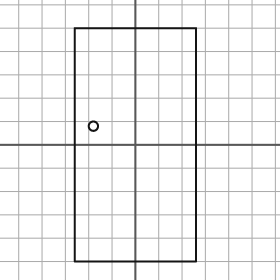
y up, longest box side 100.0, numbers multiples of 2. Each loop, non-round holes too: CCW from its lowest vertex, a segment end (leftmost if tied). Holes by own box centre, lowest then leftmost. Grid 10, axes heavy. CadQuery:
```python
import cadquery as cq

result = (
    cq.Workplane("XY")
    .moveTo(-26.0, -50.0)
    .lineTo(26.0, -50.0)
    .lineTo(26.0, 50.0)
    .lineTo(-26.0, 50.0)
    .close()
    .moveTo(-18.0, 8.0)
    .circle(2.0)
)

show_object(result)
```